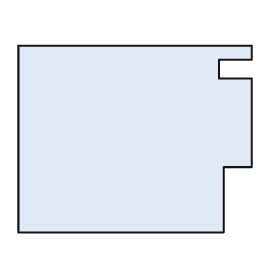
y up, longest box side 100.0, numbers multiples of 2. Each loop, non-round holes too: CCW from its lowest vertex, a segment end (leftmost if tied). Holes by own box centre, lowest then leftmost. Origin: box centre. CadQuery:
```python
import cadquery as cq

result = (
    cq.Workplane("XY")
    .moveTo(-50.0, -40.0)
    .lineTo(38.0, -40.0)
    .lineTo(38.0, -12.0)
    .lineTo(50.0, -12.0)
    .lineTo(50.0, 26.0)
    .lineTo(36.0, 26.0)
    .lineTo(36.0, 34.0)
    .lineTo(50.0, 34.0)
    .lineTo(50.0, 40.0)
    .lineTo(-50.0, 40.0)
    .close()
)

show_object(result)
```